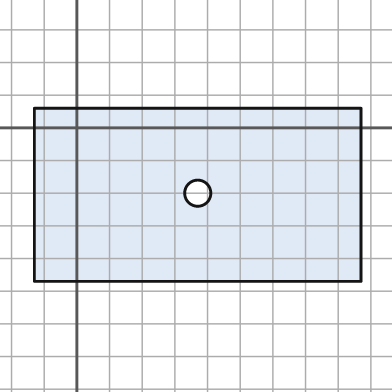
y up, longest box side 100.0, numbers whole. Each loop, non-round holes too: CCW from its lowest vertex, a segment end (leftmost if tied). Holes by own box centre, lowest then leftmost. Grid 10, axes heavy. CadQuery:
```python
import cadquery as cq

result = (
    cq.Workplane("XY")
    .moveTo(-13.0, -47.0)
    .lineTo(87.0, -47.0)
    .lineTo(87.0, 6.0)
    .lineTo(-13.0, 6.0)
    .close()
    .moveTo(37.0, -20.0)
    .circle(4.0)
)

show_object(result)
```